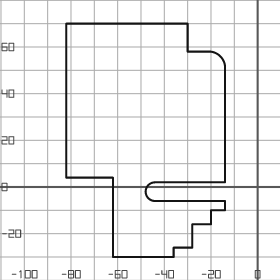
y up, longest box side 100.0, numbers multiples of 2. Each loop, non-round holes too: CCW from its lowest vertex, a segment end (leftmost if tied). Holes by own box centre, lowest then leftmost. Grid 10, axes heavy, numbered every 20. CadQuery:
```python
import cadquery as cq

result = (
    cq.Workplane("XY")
    .moveTo(-62.0, -30.0)
    .lineTo(-36.0, -30.0)
    .lineTo(-36.0, -26.0)
    .lineTo(-28.0, -26.0)
    .lineTo(-28.0, -16.0)
    .lineTo(-20.0, -16.0)
    .lineTo(-20.0, -10.0)
    .lineTo(-14.0, -10.0)
    .lineTo(-14.0, -6.0)
    .lineTo(-44.0, -6.0)
    .threePointArc((-48.0, -2.0), (-44.0, 2.0))
    .lineTo(-14.0, 2.0)
    .lineTo(-14.0, 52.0)
    .threePointArc((-16.0, 56.0), (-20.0, 58.0))
    .lineTo(-30.0, 58.0)
    .lineTo(-30.0, 70.0)
    .lineTo(-82.0, 70.0)
    .lineTo(-82.0, 4.0)
    .lineTo(-62.0, 4.0)
    .close()
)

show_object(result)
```